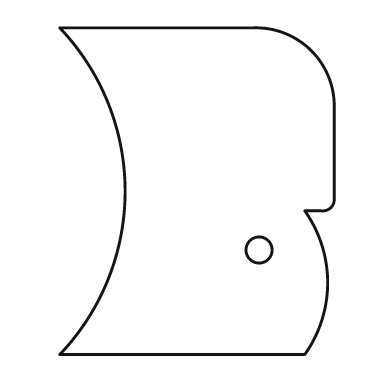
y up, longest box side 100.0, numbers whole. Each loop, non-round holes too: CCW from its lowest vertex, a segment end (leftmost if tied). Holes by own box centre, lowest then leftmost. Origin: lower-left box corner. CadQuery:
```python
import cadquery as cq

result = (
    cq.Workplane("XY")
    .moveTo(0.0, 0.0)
    .lineTo(75.0, 0.0)
    .threePointArc((82.0, 22.0), (75.0, 44.0))
    .lineTo(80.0, 44.0)
    .threePointArc((83.0, 45.0), (84.0, 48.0))
    .lineTo(84.0, 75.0)
    .threePointArc((77.0, 93.0), (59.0, 100.0))
    .lineTo(0.0, 100.0)
    .threePointArc((20.0, 50.0), (0.0, 0.0))
    .close()
    .moveTo(61.0, 32.0)
    .circle(4.0)
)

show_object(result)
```